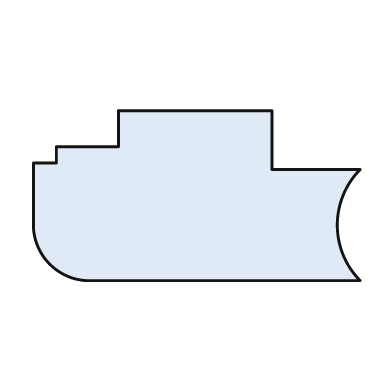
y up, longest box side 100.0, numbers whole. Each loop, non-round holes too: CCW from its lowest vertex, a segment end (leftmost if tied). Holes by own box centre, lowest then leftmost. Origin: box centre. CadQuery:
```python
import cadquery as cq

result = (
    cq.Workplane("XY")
    .moveTo(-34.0, -26.0)
    .lineTo(50.0, -26.0)
    .threePointArc((43.0, -9.0), (50.0, 8.0))
    .lineTo(23.0, 8.0)
    .lineTo(23.0, 26.0)
    .lineTo(-24.0, 26.0)
    .lineTo(-24.0, 15.0)
    .lineTo(-43.0, 15.0)
    .lineTo(-43.0, 10.0)
    .lineTo(-50.0, 10.0)
    .lineTo(-50.0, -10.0)
    .threePointArc((-45.0, -21.0), (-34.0, -26.0))
    .close()
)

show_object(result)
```